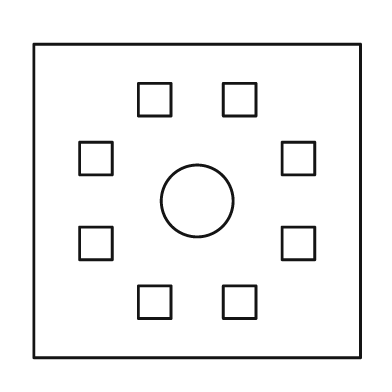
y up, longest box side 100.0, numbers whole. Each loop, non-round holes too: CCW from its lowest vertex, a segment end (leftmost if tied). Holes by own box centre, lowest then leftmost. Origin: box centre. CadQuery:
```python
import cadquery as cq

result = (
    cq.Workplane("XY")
    .moveTo(-50.0, -48.0)
    .lineTo(50.0, -48.0)
    .lineTo(50.0, 48.0)
    .lineTo(-50.0, 48.0)
    .close()
    .moveTo(-18.0, -36.0)
    .lineTo(-8.0, -36.0)
    .lineTo(-8.0, -26.0)
    .lineTo(-18.0, -26.0)
    .close()
    .moveTo(8.0, -36.0)
    .lineTo(18.0, -36.0)
    .lineTo(18.0, -26.0)
    .lineTo(8.0, -26.0)
    .close()
    .moveTo(-36.0, -18.0)
    .lineTo(-26.0, -18.0)
    .lineTo(-26.0, -8.0)
    .lineTo(-36.0, -8.0)
    .close()
    .moveTo(26.0, -18.0)
    .lineTo(36.0, -18.0)
    .lineTo(36.0, -8.0)
    .lineTo(26.0, -8.0)
    .close()
    .moveTo(0.0, 0.0)
    .circle(11.0)
    .moveTo(-36.0, 8.0)
    .lineTo(-26.0, 8.0)
    .lineTo(-26.0, 18.0)
    .lineTo(-36.0, 18.0)
    .close()
    .moveTo(26.0, 8.0)
    .lineTo(36.0, 8.0)
    .lineTo(36.0, 18.0)
    .lineTo(26.0, 18.0)
    .close()
    .moveTo(-18.0, 26.0)
    .lineTo(-8.0, 26.0)
    .lineTo(-8.0, 36.0)
    .lineTo(-18.0, 36.0)
    .close()
    .moveTo(8.0, 26.0)
    .lineTo(18.0, 26.0)
    .lineTo(18.0, 36.0)
    .lineTo(8.0, 36.0)
    .close()
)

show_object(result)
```